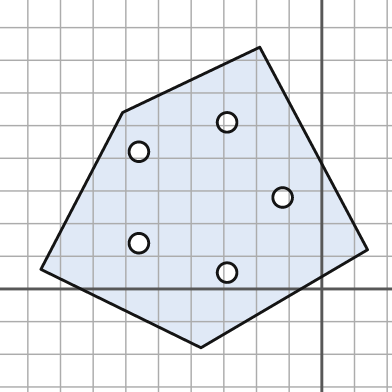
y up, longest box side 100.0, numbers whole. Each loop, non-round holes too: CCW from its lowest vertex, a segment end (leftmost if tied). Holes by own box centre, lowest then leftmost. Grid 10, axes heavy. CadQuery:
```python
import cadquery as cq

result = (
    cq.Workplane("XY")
    .moveTo(-37.0, -18.0)
    .lineTo(14.0, 12.0)
    .lineTo(-19.0, 74.0)
    .lineTo(-61.0, 54.0)
    .lineTo(-86.0, 6.0)
    .close()
    .moveTo(-29.0, 5.0)
    .circle(3.0)
    .moveTo(-56.0, 14.0)
    .circle(3.0)
    .moveTo(-12.0, 28.0)
    .circle(3.0)
    .moveTo(-56.0, 42.0)
    .circle(3.0)
    .moveTo(-29.0, 51.0)
    .circle(3.0)
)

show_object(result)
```